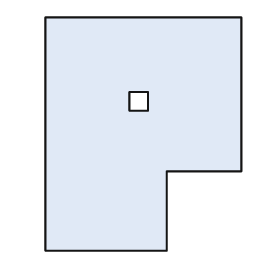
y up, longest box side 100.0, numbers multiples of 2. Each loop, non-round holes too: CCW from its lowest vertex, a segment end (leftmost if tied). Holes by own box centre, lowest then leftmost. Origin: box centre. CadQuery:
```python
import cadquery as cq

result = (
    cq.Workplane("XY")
    .moveTo(-42.0, -50.0)
    .lineTo(10.0, -50.0)
    .lineTo(10.0, -16.0)
    .lineTo(42.0, -16.0)
    .lineTo(42.0, 50.0)
    .lineTo(-42.0, 50.0)
    .close()
    .moveTo(-6.0, 10.0)
    .lineTo(2.0, 10.0)
    .lineTo(2.0, 18.0)
    .lineTo(-6.0, 18.0)
    .close()
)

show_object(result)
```